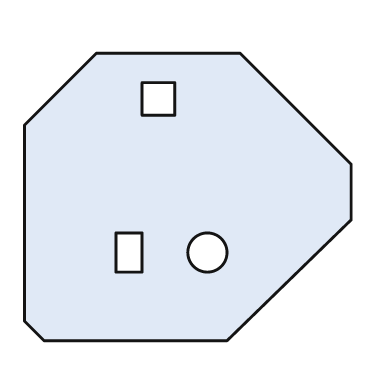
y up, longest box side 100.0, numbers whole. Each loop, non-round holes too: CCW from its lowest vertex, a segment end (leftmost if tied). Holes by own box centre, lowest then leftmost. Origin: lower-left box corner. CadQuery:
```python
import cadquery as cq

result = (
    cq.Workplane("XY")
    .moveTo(6.0, 0.0)
    .lineTo(62.0, 0.0)
    .lineTo(100.0, 37.0)
    .lineTo(100.0, 54.0)
    .lineTo(66.0, 88.0)
    .lineTo(22.0, 88.0)
    .lineTo(0.0, 66.0)
    .lineTo(0.0, 6.0)
    .close()
    .moveTo(28.0, 21.0)
    .lineTo(36.0, 21.0)
    .lineTo(36.0, 33.0)
    .lineTo(28.0, 33.0)
    .close()
    .moveTo(56.0, 27.0)
    .circle(6.0)
    .moveTo(36.0, 69.0)
    .lineTo(46.0, 69.0)
    .lineTo(46.0, 79.0)
    .lineTo(36.0, 79.0)
    .close()
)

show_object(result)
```